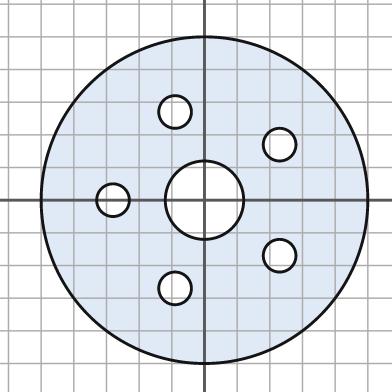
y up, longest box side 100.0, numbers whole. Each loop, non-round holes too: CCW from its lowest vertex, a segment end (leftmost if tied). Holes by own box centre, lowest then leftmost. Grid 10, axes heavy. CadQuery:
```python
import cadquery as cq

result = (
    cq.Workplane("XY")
    .moveTo(0.0, 0.0)
    .circle(50.0)
    .moveTo(-9.0, -27.0)
    .circle(5.0)
    .moveTo(23.0, -17.0)
    .circle(5.0)
    .moveTo(-28.0, 0.0)
    .circle(5.0)
    .moveTo(0.0, 0.0)
    .circle(12.0)
    .moveTo(23.0, 17.0)
    .circle(5.0)
    .moveTo(-9.0, 27.0)
    .circle(5.0)
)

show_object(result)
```